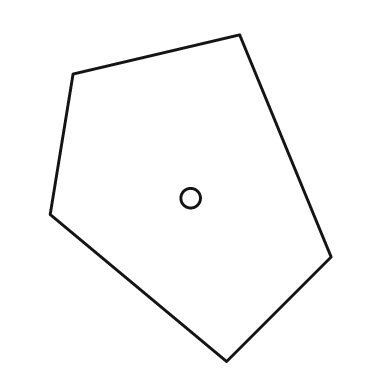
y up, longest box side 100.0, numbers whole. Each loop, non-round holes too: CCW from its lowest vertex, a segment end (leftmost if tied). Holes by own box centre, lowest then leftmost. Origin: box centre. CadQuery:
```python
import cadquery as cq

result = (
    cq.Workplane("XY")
    .moveTo(11.0, -50.0)
    .lineTo(43.0, -18.0)
    .lineTo(15.0, 50.0)
    .lineTo(-36.0, 38.0)
    .lineTo(-43.0, -5.0)
    .close()
    .moveTo(0.0, 0.0)
    .circle(3.0)
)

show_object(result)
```